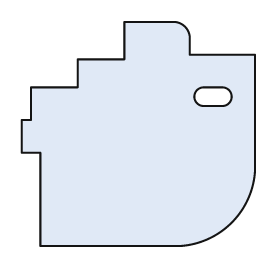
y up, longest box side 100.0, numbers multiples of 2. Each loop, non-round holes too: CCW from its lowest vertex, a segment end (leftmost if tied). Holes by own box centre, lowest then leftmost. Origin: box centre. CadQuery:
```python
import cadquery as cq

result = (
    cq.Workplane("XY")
    .moveTo(-42.0, -48.0)
    .lineTo(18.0, -48.0)
    .threePointArc((40.0, -38.0), (50.0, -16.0))
    .lineTo(50.0, 34.0)
    .lineTo(22.0, 34.0)
    .lineTo(22.0, 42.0)
    .threePointArc((20.0, 46.0), (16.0, 48.0))
    .lineTo(-6.0, 48.0)
    .lineTo(-6.0, 32.0)
    .lineTo(-26.0, 32.0)
    .lineTo(-26.0, 20.0)
    .lineTo(-46.0, 20.0)
    .lineTo(-46.0, 6.0)
    .lineTo(-50.0, 6.0)
    .lineTo(-50.0, -8.0)
    .lineTo(-42.0, -8.0)
    .close()
    .moveTo(28.0, 12.0)
    .lineTo(36.0, 12.0)
    .threePointArc((40.0, 16.0), (36.0, 20.0))
    .lineTo(28.0, 20.0)
    .threePointArc((24.0, 16.0), (28.0, 12.0))
    .close()
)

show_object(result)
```